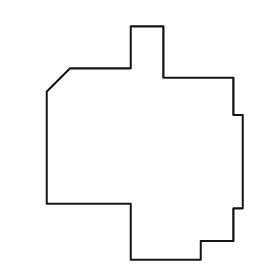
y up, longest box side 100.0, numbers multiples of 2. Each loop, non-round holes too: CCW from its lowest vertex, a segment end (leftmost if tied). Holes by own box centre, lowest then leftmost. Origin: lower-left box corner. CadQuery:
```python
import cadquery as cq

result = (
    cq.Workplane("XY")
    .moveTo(36.0, 0.0)
    .lineTo(66.0, 0.0)
    .lineTo(66.0, 8.0)
    .lineTo(80.0, 8.0)
    .lineTo(80.0, 22.0)
    .lineTo(84.0, 22.0)
    .lineTo(84.0, 62.0)
    .lineTo(80.0, 62.0)
    .lineTo(80.0, 78.0)
    .lineTo(50.0, 78.0)
    .lineTo(50.0, 100.0)
    .lineTo(36.0, 100.0)
    .lineTo(36.0, 82.0)
    .lineTo(10.0, 82.0)
    .lineTo(0.0, 72.0)
    .lineTo(0.0, 24.0)
    .lineTo(36.0, 24.0)
    .close()
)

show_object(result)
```